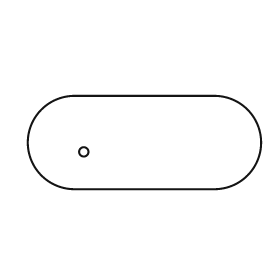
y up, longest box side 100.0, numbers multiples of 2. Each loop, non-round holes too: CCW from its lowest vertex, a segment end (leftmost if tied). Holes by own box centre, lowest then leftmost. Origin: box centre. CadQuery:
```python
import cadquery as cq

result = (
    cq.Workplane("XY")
    .moveTo(-30.0, -20.0)
    .lineTo(30.0, -20.0)
    .threePointArc((50.0, 0.0), (30.0, 20.0))
    .lineTo(-30.0, 20.0)
    .threePointArc((-50.0, 0.0), (-30.0, -20.0))
    .close()
    .moveTo(-26.0, -4.0)
    .circle(2.0)
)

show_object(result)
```